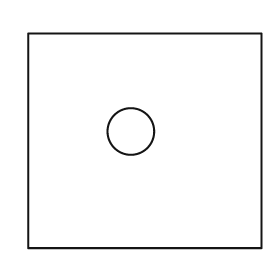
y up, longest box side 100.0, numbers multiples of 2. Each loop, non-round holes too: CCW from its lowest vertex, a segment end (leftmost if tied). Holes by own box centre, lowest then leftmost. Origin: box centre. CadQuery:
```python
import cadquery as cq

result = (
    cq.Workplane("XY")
    .moveTo(-50.0, -46.0)
    .lineTo(50.0, -46.0)
    .lineTo(50.0, 46.0)
    .lineTo(-50.0, 46.0)
    .close()
    .moveTo(-6.0, 4.0)
    .circle(10.0)
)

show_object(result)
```